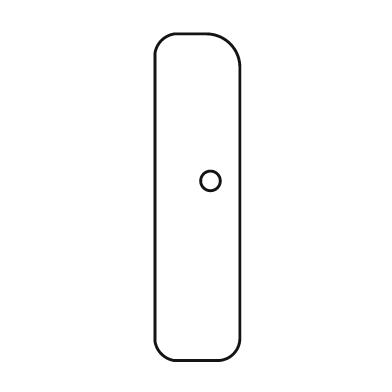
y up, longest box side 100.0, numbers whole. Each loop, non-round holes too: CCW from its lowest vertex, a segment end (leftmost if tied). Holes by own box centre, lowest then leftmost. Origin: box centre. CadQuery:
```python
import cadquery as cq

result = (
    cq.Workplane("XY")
    .moveTo(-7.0, -50.0)
    .lineTo(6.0, -50.0)
    .threePointArc((11.0, -48.0), (13.0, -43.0))
    .lineTo(13.0, 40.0)
    .threePointArc((10.0, 47.0), (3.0, 50.0))
    .lineTo(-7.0, 50.0)
    .threePointArc((-11.0, 48.0), (-13.0, 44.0))
    .lineTo(-13.0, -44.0)
    .threePointArc((-11.0, -48.0), (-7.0, -50.0))
    .close()
    .moveTo(4.0, 5.0)
    .circle(3.0)
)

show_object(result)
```